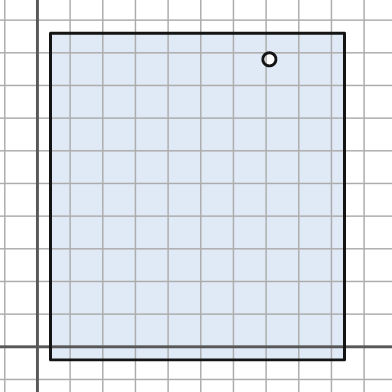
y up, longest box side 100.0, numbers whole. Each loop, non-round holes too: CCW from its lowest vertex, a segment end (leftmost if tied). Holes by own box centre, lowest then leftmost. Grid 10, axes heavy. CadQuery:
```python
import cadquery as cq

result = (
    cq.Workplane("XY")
    .moveTo(4.0, -4.0)
    .lineTo(94.0, -4.0)
    .lineTo(94.0, 96.0)
    .lineTo(4.0, 96.0)
    .close()
    .moveTo(71.0, 88.0)
    .circle(2.0)
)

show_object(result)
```